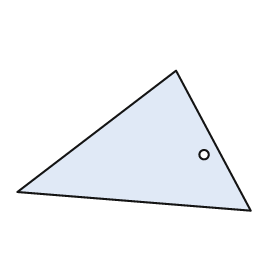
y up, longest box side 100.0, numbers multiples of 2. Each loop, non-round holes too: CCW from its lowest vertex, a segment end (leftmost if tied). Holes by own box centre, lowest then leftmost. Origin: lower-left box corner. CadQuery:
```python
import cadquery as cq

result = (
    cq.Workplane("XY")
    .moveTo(100.0, 0.0)
    .lineTo(68.0, 60.0)
    .lineTo(0.0, 8.0)
    .close()
    .moveTo(80.0, 24.0)
    .circle(2.0)
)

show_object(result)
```